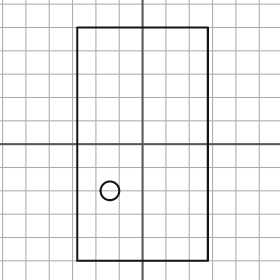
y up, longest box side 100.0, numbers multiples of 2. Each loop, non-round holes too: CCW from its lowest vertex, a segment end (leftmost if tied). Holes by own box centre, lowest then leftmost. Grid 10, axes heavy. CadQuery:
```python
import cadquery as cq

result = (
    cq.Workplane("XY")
    .moveTo(-28.0, -50.0)
    .lineTo(28.0, -50.0)
    .lineTo(28.0, 50.0)
    .lineTo(-28.0, 50.0)
    .close()
    .moveTo(-14.0, -20.0)
    .circle(4.0)
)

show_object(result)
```